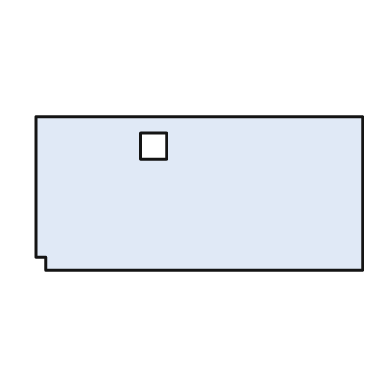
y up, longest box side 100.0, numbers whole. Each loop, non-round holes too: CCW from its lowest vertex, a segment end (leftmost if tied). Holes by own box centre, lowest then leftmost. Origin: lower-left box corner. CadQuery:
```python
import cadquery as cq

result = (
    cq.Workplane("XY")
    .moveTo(3.0, 0.0)
    .lineTo(100.0, 0.0)
    .lineTo(100.0, 47.0)
    .lineTo(0.0, 47.0)
    .lineTo(0.0, 4.0)
    .lineTo(3.0, 4.0)
    .close()
    .moveTo(32.0, 34.0)
    .lineTo(40.0, 34.0)
    .lineTo(40.0, 42.0)
    .lineTo(32.0, 42.0)
    .close()
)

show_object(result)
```